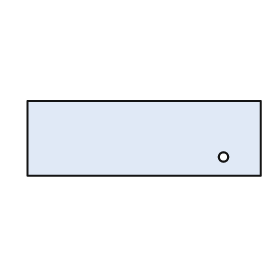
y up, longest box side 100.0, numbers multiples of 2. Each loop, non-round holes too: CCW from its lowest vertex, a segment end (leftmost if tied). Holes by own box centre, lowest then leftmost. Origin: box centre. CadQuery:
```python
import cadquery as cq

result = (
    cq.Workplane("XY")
    .moveTo(-50.0, -16.0)
    .lineTo(50.0, -16.0)
    .lineTo(50.0, 16.0)
    .lineTo(-50.0, 16.0)
    .close()
    .moveTo(34.0, -8.0)
    .circle(2.0)
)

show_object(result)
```